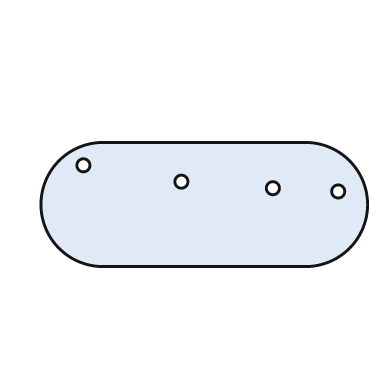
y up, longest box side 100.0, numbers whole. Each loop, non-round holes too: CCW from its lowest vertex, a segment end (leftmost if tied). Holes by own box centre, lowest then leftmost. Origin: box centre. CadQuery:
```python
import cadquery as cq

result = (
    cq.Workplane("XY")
    .moveTo(-31.0, -19.0)
    .lineTo(31.0, -19.0)
    .threePointArc((50.0, 0.0), (31.0, 19.0))
    .lineTo(-31.0, 19.0)
    .threePointArc((-50.0, 0.0), (-31.0, -19.0))
    .close()
    .moveTo(41.0, 4.0)
    .circle(2.0)
    .moveTo(21.0, 5.0)
    .circle(2.0)
    .moveTo(-7.0, 7.0)
    .circle(2.0)
    .moveTo(-37.0, 12.0)
    .circle(2.0)
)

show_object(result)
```